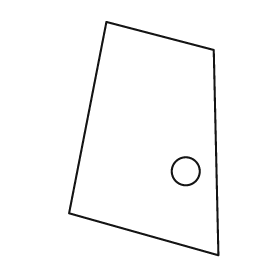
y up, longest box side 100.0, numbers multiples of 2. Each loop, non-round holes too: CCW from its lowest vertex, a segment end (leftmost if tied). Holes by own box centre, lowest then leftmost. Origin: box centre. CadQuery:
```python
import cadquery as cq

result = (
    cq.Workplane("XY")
    .moveTo(32.0, -50.0)
    .lineTo(30.0, 38.0)
    .lineTo(-16.0, 50.0)
    .lineTo(-32.0, -32.0)
    .close()
    .moveTo(18.0, -14.0)
    .circle(6.0)
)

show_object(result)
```